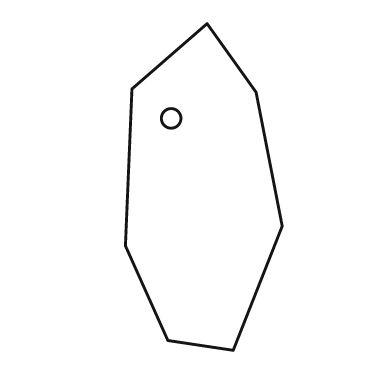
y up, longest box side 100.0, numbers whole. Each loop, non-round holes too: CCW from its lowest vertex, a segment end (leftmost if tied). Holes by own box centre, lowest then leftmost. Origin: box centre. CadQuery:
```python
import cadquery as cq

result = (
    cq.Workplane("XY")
    .moveTo(9.0, -50.0)
    .lineTo(24.0, -12.0)
    .lineTo(16.0, 29.0)
    .lineTo(1.0, 50.0)
    .lineTo(-22.0, 30.0)
    .lineTo(-24.0, -18.0)
    .lineTo(-11.0, -47.0)
    .close()
    .moveTo(-10.0, 21.0)
    .circle(3.0)
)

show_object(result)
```